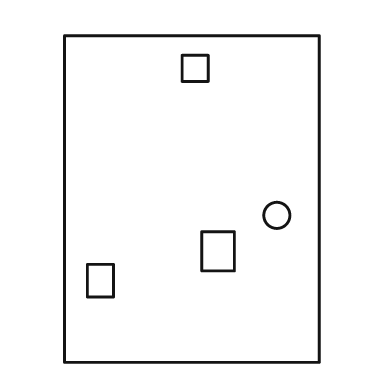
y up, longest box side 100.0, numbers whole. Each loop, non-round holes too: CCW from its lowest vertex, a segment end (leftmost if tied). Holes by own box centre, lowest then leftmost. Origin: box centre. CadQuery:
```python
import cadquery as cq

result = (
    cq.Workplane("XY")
    .moveTo(-39.0, -50.0)
    .lineTo(39.0, -50.0)
    .lineTo(39.0, 50.0)
    .lineTo(-39.0, 50.0)
    .close()
    .moveTo(-32.0, -30.0)
    .lineTo(-24.0, -30.0)
    .lineTo(-24.0, -20.0)
    .lineTo(-32.0, -20.0)
    .close()
    .moveTo(3.0, -22.0)
    .lineTo(13.0, -22.0)
    .lineTo(13.0, -10.0)
    .lineTo(3.0, -10.0)
    .close()
    .moveTo(26.0, -5.0)
    .circle(4.0)
    .moveTo(-3.0, 36.0)
    .lineTo(5.0, 36.0)
    .lineTo(5.0, 44.0)
    .lineTo(-3.0, 44.0)
    .close()
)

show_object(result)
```